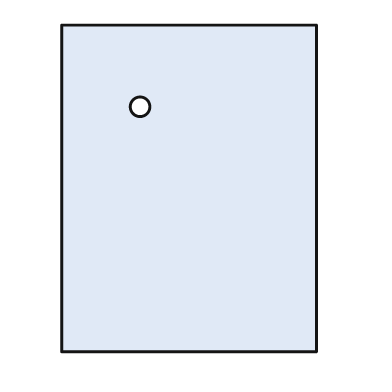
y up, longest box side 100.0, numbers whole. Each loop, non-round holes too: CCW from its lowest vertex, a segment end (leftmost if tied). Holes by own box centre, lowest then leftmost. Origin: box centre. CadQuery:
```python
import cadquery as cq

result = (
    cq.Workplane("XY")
    .moveTo(-39.0, -50.0)
    .lineTo(39.0, -50.0)
    .lineTo(39.0, 50.0)
    .lineTo(-39.0, 50.0)
    .close()
    .moveTo(-15.0, 25.0)
    .circle(3.0)
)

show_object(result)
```